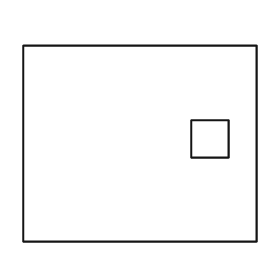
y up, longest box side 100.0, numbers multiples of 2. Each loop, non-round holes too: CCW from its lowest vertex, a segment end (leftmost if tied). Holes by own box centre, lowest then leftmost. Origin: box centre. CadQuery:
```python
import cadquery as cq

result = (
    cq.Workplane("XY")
    .moveTo(-50.0, -42.0)
    .lineTo(50.0, -42.0)
    .lineTo(50.0, 42.0)
    .lineTo(-50.0, 42.0)
    .close()
    .moveTo(22.0, -6.0)
    .lineTo(38.0, -6.0)
    .lineTo(38.0, 10.0)
    .lineTo(22.0, 10.0)
    .close()
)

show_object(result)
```